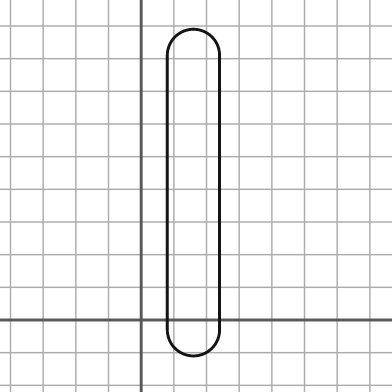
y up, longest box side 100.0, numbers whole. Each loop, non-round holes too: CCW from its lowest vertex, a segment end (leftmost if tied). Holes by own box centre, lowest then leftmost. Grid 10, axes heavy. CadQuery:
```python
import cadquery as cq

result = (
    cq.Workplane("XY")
    .moveTo(8.0, -3.0)
    .threePointArc((16.0, -11.0), (24.0, -3.0))
    .lineTo(24.0, 81.0)
    .threePointArc((16.0, 89.0), (8.0, 81.0))
    .close()
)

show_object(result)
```